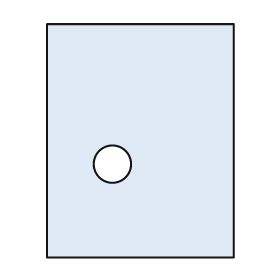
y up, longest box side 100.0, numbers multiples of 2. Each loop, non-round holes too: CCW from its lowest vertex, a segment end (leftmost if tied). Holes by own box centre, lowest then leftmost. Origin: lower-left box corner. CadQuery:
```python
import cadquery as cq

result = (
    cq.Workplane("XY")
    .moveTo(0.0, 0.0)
    .lineTo(80.0, 0.0)
    .lineTo(80.0, 100.0)
    .lineTo(0.0, 100.0)
    .close()
    .moveTo(28.0, 40.0)
    .circle(8.0)
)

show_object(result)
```